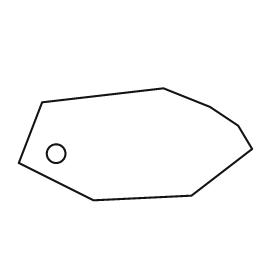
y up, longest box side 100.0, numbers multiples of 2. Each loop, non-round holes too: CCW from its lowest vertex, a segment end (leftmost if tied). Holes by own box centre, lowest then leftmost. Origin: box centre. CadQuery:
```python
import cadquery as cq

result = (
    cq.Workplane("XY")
    .moveTo(-18.0, -24.0)
    .lineTo(24.0, -22.0)
    .lineTo(50.0, -2.0)
    .lineTo(44.0, 8.0)
    .lineTo(32.0, 16.0)
    .lineTo(12.0, 24.0)
    .lineTo(-40.0, 18.0)
    .lineTo(-50.0, -8.0)
    .close()
    .moveTo(-34.0, -4.0)
    .circle(4.0)
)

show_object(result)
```